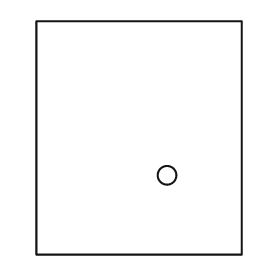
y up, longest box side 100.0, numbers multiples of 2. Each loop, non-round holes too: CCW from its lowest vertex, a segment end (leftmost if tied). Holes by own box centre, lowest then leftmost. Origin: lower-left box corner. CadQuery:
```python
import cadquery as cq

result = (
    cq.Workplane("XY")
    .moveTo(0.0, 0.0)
    .lineTo(88.0, 0.0)
    .lineTo(88.0, 100.0)
    .lineTo(0.0, 100.0)
    .close()
    .moveTo(56.0, 34.0)
    .circle(4.0)
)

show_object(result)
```